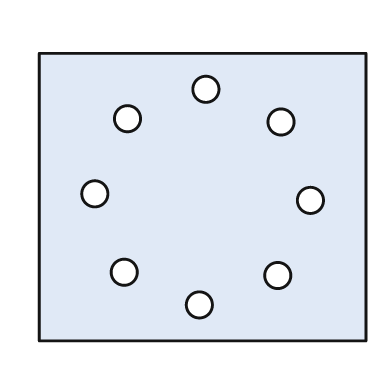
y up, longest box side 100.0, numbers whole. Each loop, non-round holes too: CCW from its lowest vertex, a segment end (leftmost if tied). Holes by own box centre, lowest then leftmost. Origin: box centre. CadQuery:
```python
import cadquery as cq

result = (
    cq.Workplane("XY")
    .moveTo(-50.0, -44.0)
    .lineTo(50.0, -44.0)
    .lineTo(50.0, 44.0)
    .lineTo(-50.0, 44.0)
    .close()
    .moveTo(-1.0, -33.0)
    .circle(4.0)
    .moveTo(23.0, -24.0)
    .circle(4.0)
    .moveTo(-24.0, -23.0)
    .circle(4.0)
    .moveTo(33.0, -1.0)
    .circle(4.0)
    .moveTo(-33.0, 1.0)
    .circle(4.0)
    .moveTo(24.0, 23.0)
    .circle(4.0)
    .moveTo(-23.0, 24.0)
    .circle(4.0)
    .moveTo(1.0, 33.0)
    .circle(4.0)
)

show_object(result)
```